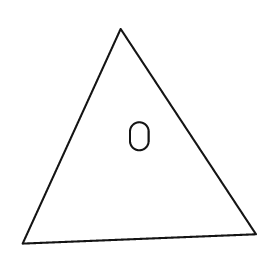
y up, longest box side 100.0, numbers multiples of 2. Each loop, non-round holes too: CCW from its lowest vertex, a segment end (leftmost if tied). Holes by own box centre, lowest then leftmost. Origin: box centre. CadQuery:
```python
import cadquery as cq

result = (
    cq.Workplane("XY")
    .moveTo(-50.0, -46.0)
    .lineTo(50.0, -42.0)
    .lineTo(-8.0, 46.0)
    .close()
    .moveTo(-4.0, -2.0)
    .threePointArc((0.0, -6.0), (4.0, -2.0))
    .lineTo(4.0, 2.0)
    .threePointArc((0.0, 6.0), (-4.0, 2.0))
    .close()
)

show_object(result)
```